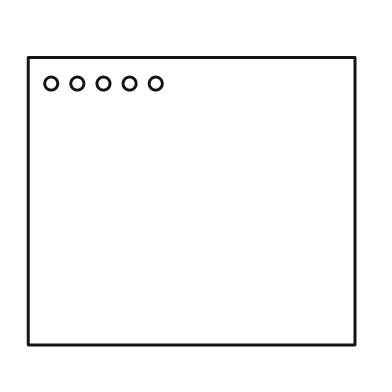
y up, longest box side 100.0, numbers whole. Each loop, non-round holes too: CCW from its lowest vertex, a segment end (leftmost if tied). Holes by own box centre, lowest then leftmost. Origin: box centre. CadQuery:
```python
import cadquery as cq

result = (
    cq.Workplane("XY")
    .moveTo(-50.0, -44.0)
    .lineTo(50.0, -44.0)
    .lineTo(50.0, 44.0)
    .lineTo(-50.0, 44.0)
    .close()
    .moveTo(-43.0, 36.0)
    .circle(2.0)
    .moveTo(-35.0, 36.0)
    .circle(2.0)
    .moveTo(-27.0, 36.0)
    .circle(2.0)
    .moveTo(-19.0, 36.0)
    .circle(2.0)
    .moveTo(-11.0, 36.0)
    .circle(2.0)
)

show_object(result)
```